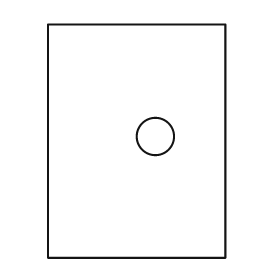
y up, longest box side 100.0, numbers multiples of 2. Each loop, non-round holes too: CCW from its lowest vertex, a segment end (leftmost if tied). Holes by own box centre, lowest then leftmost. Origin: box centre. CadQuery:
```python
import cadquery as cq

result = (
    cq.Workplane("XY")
    .moveTo(-38.0, -50.0)
    .lineTo(38.0, -50.0)
    .lineTo(38.0, 50.0)
    .lineTo(-38.0, 50.0)
    .close()
    .moveTo(8.0, 2.0)
    .circle(8.0)
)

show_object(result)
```